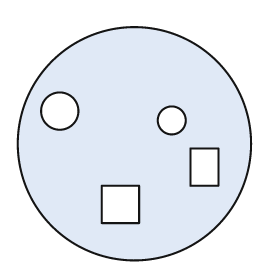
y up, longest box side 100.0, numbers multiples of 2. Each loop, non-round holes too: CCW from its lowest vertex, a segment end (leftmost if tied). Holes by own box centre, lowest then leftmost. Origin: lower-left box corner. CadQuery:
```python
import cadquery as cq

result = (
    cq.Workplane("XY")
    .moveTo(50.0, 50.0)
    .circle(50.0)
    .moveTo(36.0, 16.0)
    .lineTo(52.0, 16.0)
    .lineTo(52.0, 32.0)
    .lineTo(36.0, 32.0)
    .close()
    .moveTo(74.0, 32.0)
    .lineTo(86.0, 32.0)
    .lineTo(86.0, 48.0)
    .lineTo(74.0, 48.0)
    .close()
    .moveTo(66.0, 60.0)
    .circle(6.0)
    .moveTo(18.0, 64.0)
    .circle(8.0)
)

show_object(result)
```